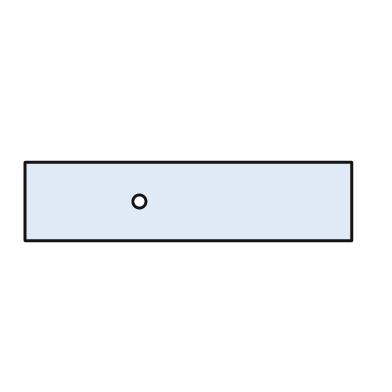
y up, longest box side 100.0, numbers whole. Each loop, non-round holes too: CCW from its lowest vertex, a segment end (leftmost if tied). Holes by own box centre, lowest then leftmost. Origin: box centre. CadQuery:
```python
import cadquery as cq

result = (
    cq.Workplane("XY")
    .moveTo(-50.0, -12.0)
    .lineTo(50.0, -12.0)
    .lineTo(50.0, 12.0)
    .lineTo(-50.0, 12.0)
    .close()
    .moveTo(-15.0, 0.0)
    .circle(2.0)
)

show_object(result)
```